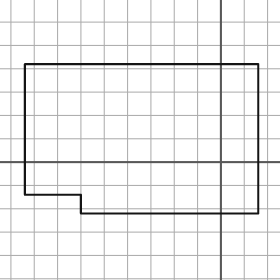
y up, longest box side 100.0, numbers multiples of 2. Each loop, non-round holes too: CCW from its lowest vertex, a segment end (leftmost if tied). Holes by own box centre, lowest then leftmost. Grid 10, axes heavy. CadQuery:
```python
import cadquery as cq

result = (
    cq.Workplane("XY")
    .moveTo(-60.0, -22.0)
    .lineTo(16.0, -22.0)
    .lineTo(16.0, 42.0)
    .lineTo(-84.0, 42.0)
    .lineTo(-84.0, -14.0)
    .lineTo(-60.0, -14.0)
    .close()
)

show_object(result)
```